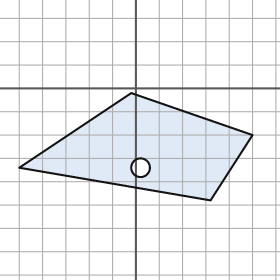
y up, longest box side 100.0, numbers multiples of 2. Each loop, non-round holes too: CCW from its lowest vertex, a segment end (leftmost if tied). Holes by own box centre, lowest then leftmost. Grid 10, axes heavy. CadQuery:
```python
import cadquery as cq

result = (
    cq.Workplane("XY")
    .moveTo(32.0, -48.0)
    .lineTo(50.0, -20.0)
    .lineTo(-2.0, -2.0)
    .lineTo(-50.0, -34.0)
    .close()
    .moveTo(2.0, -34.0)
    .circle(4.0)
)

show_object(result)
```